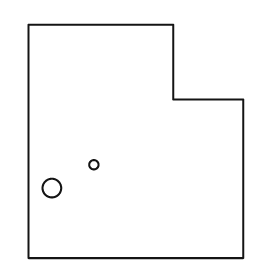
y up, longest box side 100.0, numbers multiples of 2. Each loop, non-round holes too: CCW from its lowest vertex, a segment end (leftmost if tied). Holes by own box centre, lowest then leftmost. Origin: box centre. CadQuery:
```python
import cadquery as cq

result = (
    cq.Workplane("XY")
    .moveTo(-46.0, -50.0)
    .lineTo(46.0, -50.0)
    .lineTo(46.0, 18.0)
    .lineTo(16.0, 18.0)
    .lineTo(16.0, 50.0)
    .lineTo(-46.0, 50.0)
    .close()
    .moveTo(-36.0, -20.0)
    .circle(4.0)
    .moveTo(-18.0, -10.0)
    .circle(2.0)
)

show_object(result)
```